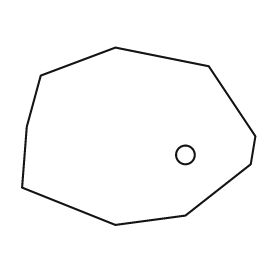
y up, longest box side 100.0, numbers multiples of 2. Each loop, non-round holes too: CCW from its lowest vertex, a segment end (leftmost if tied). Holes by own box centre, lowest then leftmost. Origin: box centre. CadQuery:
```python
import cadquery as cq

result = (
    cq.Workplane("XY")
    .moveTo(-10.0, -38.0)
    .lineTo(20.0, -34.0)
    .lineTo(48.0, -12.0)
    .lineTo(50.0, 0.0)
    .lineTo(30.0, 30.0)
    .lineTo(-10.0, 38.0)
    .lineTo(-42.0, 26.0)
    .lineTo(-48.0, 4.0)
    .lineTo(-50.0, -22.0)
    .close()
    .moveTo(20.0, -8.0)
    .circle(4.0)
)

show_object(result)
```